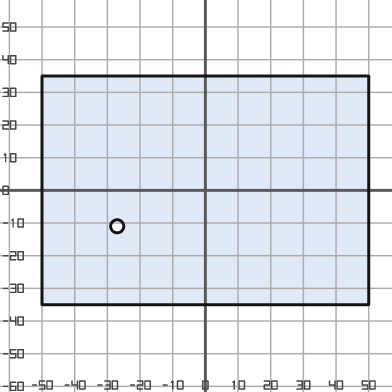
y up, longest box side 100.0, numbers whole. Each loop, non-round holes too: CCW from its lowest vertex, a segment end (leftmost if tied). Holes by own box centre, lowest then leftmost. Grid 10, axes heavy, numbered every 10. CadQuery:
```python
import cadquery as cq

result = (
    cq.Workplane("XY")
    .moveTo(-50.0, -35.0)
    .lineTo(50.0, -35.0)
    .lineTo(50.0, 35.0)
    .lineTo(-50.0, 35.0)
    .close()
    .moveTo(-27.0, -11.0)
    .circle(2.0)
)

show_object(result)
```